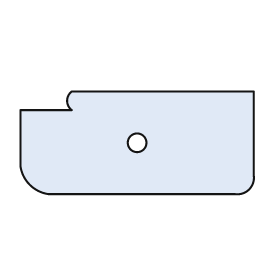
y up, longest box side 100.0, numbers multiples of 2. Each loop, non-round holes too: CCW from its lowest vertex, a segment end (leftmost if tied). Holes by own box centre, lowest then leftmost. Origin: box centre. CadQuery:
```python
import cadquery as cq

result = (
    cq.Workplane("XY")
    .moveTo(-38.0, -22.0)
    .lineTo(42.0, -22.0)
    .threePointArc((48.0, -20.0), (50.0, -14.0))
    .lineTo(50.0, 22.0)
    .lineTo(-28.0, 22.0)
    .threePointArc((-30.0, 18.0), (-28.0, 14.0))
    .lineTo(-50.0, 14.0)
    .lineTo(-50.0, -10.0)
    .threePointArc((-46.0, -18.0), (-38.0, -22.0))
    .close()
    .moveTo(0.0, 0.0)
    .circle(4.0)
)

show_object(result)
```